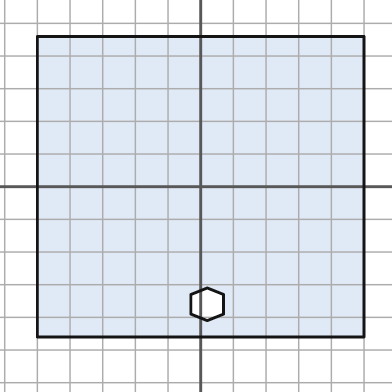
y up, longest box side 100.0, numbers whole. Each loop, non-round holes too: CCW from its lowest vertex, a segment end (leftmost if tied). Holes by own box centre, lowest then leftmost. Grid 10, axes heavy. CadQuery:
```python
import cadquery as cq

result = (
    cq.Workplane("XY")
    .moveTo(-50.0, -46.0)
    .lineTo(50.0, -46.0)
    .lineTo(50.0, 46.0)
    .lineTo(-50.0, 46.0)
    .close()
    .moveTo(2.0, -41.0)
    .lineTo(7.0, -39.0)
    .lineTo(7.0, -33.0)
    .lineTo(2.0, -31.0)
    .lineTo(-3.0, -33.0)
    .lineTo(-3.0, -39.0)
    .close()
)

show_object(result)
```